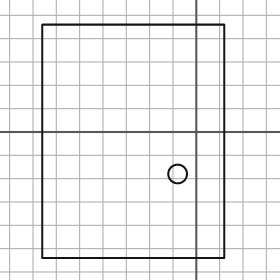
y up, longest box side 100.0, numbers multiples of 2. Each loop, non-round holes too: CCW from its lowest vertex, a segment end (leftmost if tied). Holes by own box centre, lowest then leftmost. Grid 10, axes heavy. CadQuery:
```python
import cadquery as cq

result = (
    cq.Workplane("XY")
    .moveTo(-66.0, -54.0)
    .lineTo(12.0, -54.0)
    .lineTo(12.0, 46.0)
    .lineTo(-66.0, 46.0)
    .close()
    .moveTo(-8.0, -18.0)
    .circle(4.0)
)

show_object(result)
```